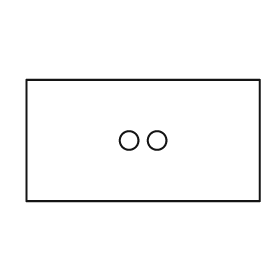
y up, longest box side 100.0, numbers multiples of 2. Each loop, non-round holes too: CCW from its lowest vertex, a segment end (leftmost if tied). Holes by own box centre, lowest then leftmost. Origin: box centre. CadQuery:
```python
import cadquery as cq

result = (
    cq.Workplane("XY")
    .moveTo(-50.0, -26.0)
    .lineTo(50.0, -26.0)
    .lineTo(50.0, 26.0)
    .lineTo(-50.0, 26.0)
    .close()
    .moveTo(-6.0, 0.0)
    .circle(4.0)
    .moveTo(6.0, 0.0)
    .circle(4.0)
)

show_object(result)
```